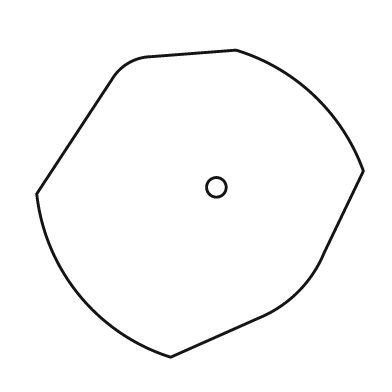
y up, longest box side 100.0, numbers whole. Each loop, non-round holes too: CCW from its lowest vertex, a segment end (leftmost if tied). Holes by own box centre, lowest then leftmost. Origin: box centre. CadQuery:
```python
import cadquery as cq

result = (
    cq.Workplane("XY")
    .moveTo(-9.0, -47.0)
    .lineTo(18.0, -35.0)
    .threePointArc((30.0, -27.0), (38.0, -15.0))
    .lineTo(50.0, 10.0)
    .threePointArc((35.0, 33.0), (11.0, 47.0))
    .lineTo(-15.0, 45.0)
    .threePointArc((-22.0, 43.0), (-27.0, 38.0))
    .lineTo(-50.0, 3.0)
    .threePointArc((-37.0, -28.0), (-9.0, -47.0))
    .close()
    .moveTo(5.0, 5.0)
    .circle(3.0)
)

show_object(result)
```